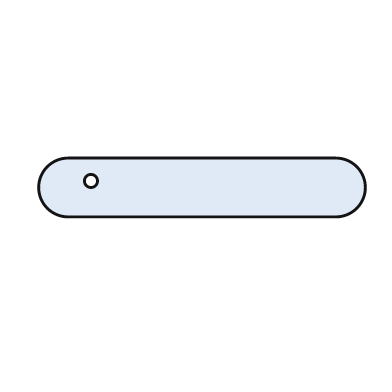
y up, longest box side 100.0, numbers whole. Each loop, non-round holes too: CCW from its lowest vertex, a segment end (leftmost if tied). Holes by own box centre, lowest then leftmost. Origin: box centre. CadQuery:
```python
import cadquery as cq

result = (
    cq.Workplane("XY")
    .moveTo(-41.0, -9.0)
    .lineTo(41.0, -9.0)
    .threePointArc((50.0, 0.0), (41.0, 9.0))
    .lineTo(-41.0, 9.0)
    .threePointArc((-50.0, 0.0), (-41.0, -9.0))
    .close()
    .moveTo(-34.0, 2.0)
    .circle(2.0)
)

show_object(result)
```